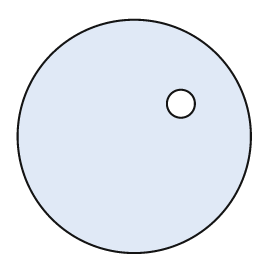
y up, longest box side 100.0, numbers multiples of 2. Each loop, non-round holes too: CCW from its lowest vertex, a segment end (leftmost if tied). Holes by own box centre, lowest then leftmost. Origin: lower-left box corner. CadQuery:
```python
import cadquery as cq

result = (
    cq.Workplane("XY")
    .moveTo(50.0, 50.0)
    .circle(50.0)
    .moveTo(70.0, 64.0)
    .circle(6.0)
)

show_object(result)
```